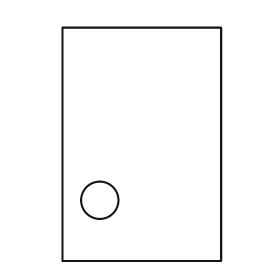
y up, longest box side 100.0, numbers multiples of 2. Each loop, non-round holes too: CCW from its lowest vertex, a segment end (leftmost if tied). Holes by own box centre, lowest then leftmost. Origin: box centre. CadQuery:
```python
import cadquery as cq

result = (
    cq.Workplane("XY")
    .moveTo(-34.0, -50.0)
    .lineTo(34.0, -50.0)
    .lineTo(34.0, 50.0)
    .lineTo(-34.0, 50.0)
    .close()
    .moveTo(-18.0, -24.0)
    .circle(8.0)
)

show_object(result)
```